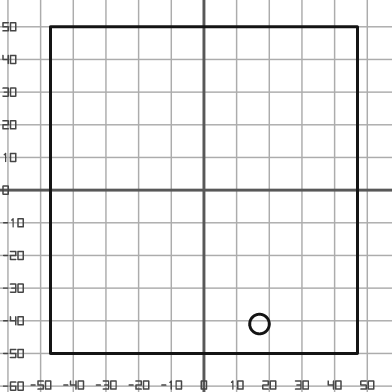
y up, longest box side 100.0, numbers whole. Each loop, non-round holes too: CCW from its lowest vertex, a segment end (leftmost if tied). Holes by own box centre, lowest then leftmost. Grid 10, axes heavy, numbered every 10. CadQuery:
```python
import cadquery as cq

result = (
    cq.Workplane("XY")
    .moveTo(-47.0, -50.0)
    .lineTo(47.0, -50.0)
    .lineTo(47.0, 50.0)
    .lineTo(-47.0, 50.0)
    .close()
    .moveTo(17.0, -41.0)
    .circle(3.0)
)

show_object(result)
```